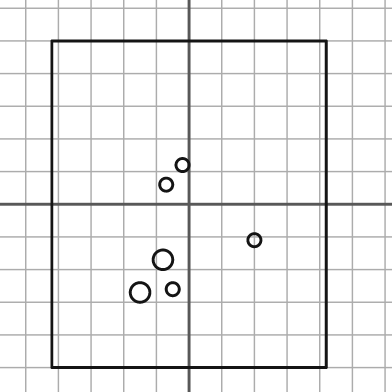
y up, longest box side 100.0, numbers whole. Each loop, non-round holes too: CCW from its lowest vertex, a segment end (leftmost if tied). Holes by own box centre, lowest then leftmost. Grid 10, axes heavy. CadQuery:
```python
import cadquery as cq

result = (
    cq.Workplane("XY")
    .moveTo(-42.0, -50.0)
    .lineTo(42.0, -50.0)
    .lineTo(42.0, 50.0)
    .lineTo(-42.0, 50.0)
    .close()
    .moveTo(-15.0, -27.0)
    .circle(3.0)
    .moveTo(-5.0, -26.0)
    .circle(2.0)
    .moveTo(-8.0, -17.0)
    .circle(3.0)
    .moveTo(20.0, -11.0)
    .circle(2.0)
    .moveTo(-7.0, 6.0)
    .circle(2.0)
    .moveTo(-2.0, 12.0)
    .circle(2.0)
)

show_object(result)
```